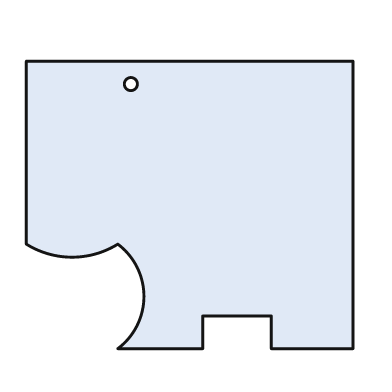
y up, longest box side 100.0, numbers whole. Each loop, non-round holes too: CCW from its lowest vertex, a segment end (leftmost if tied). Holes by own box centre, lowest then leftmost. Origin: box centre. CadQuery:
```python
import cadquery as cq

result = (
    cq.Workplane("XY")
    .moveTo(-22.0, -44.0)
    .lineTo(4.0, -44.0)
    .lineTo(4.0, -34.0)
    .lineTo(25.0, -34.0)
    .lineTo(25.0, -44.0)
    .lineTo(50.0, -44.0)
    .lineTo(50.0, 44.0)
    .lineTo(-50.0, 44.0)
    .lineTo(-50.0, -12.0)
    .threePointArc((-36.0, -16.0), (-22.0, -12.0))
    .threePointArc((-14.0, -28.0), (-22.0, -44.0))
    .close()
    .moveTo(-18.0, 37.0)
    .circle(2.0)
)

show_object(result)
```